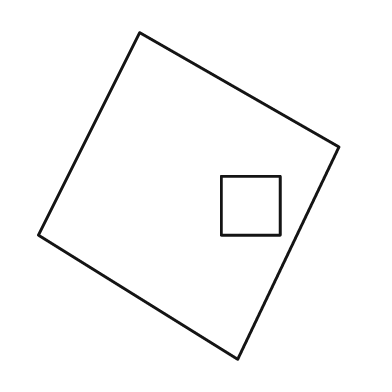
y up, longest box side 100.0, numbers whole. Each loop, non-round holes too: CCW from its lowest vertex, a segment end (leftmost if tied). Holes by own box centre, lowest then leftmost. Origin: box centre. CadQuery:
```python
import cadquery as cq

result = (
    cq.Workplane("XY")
    .moveTo(15.0, -50.0)
    .lineTo(46.0, 15.0)
    .lineTo(-15.0, 50.0)
    .lineTo(-46.0, -12.0)
    .close()
    .moveTo(10.0, -12.0)
    .lineTo(28.0, -12.0)
    .lineTo(28.0, 6.0)
    .lineTo(10.0, 6.0)
    .close()
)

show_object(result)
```